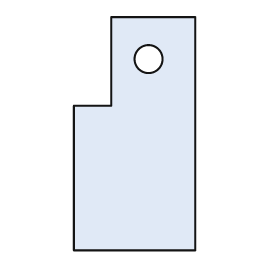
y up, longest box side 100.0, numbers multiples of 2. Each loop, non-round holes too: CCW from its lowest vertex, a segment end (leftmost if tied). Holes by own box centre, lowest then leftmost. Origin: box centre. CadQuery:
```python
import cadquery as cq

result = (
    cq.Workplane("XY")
    .moveTo(-26.0, -50.0)
    .lineTo(26.0, -50.0)
    .lineTo(26.0, 50.0)
    .lineTo(-10.0, 50.0)
    .lineTo(-10.0, 12.0)
    .lineTo(-26.0, 12.0)
    .close()
    .moveTo(6.0, 32.0)
    .circle(6.0)
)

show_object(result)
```